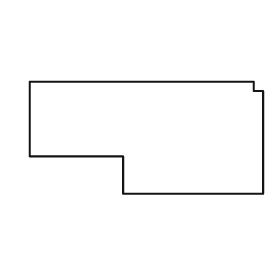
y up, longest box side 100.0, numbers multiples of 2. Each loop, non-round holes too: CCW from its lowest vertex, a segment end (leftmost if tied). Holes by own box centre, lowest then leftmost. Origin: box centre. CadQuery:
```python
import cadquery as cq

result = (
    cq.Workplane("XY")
    .moveTo(-10.0, -24.0)
    .lineTo(50.0, -24.0)
    .lineTo(50.0, 20.0)
    .lineTo(46.0, 20.0)
    .lineTo(46.0, 24.0)
    .lineTo(-50.0, 24.0)
    .lineTo(-50.0, -8.0)
    .lineTo(-10.0, -8.0)
    .close()
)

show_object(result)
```